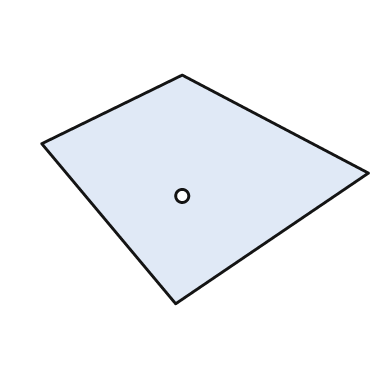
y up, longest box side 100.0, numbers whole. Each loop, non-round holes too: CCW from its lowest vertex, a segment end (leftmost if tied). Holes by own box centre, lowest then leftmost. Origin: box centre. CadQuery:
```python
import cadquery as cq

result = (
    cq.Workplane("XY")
    .moveTo(-9.0, -35.0)
    .lineTo(50.0, 5.0)
    .lineTo(-7.0, 35.0)
    .lineTo(-50.0, 14.0)
    .close()
    .moveTo(-7.0, -2.0)
    .circle(2.0)
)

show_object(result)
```